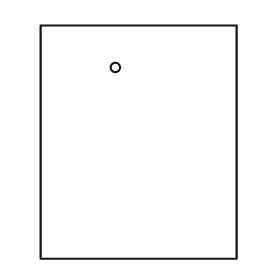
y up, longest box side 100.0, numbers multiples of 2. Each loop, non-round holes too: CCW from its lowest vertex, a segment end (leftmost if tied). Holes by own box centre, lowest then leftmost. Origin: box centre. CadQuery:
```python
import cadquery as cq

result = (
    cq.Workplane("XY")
    .moveTo(-42.0, -50.0)
    .lineTo(42.0, -50.0)
    .lineTo(42.0, 50.0)
    .lineTo(-42.0, 50.0)
    .close()
    .moveTo(-10.0, 32.0)
    .circle(2.0)
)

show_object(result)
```